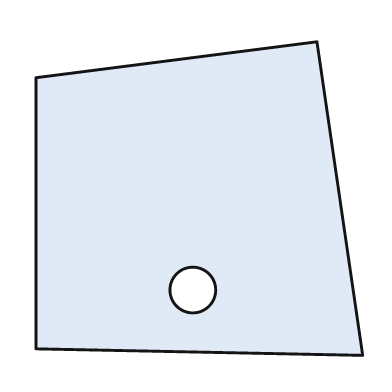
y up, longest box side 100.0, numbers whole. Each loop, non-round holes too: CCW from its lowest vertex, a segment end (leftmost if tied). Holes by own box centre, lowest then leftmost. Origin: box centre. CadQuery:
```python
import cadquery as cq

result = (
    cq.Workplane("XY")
    .moveTo(50.0, -48.0)
    .lineTo(36.0, 48.0)
    .lineTo(-50.0, 37.0)
    .lineTo(-50.0, -46.0)
    .close()
    .moveTo(-2.0, -28.0)
    .circle(7.0)
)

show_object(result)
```